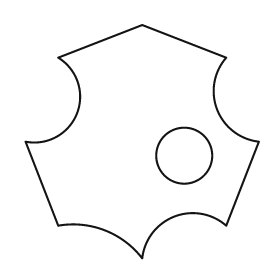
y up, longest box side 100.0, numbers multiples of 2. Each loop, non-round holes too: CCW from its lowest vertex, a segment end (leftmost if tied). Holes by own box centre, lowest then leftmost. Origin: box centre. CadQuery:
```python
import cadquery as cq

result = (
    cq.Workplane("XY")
    .moveTo(0.0, -50.0)
    .threePointArc((14.0, -32.0), (36.0, -36.0))
    .lineTo(50.0, 0.0)
    .threePointArc((32.0, 14.0), (36.0, 36.0))
    .lineTo(0.0, 50.0)
    .lineTo(-36.0, 36.0)
    .threePointArc((-28.0, 12.0), (-50.0, 0.0))
    .lineTo(-36.0, -36.0)
    .threePointArc((-16.0, -38.0), (0.0, -50.0))
    .close()
    .moveTo(18.0, -6.0)
    .circle(12.0)
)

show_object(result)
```